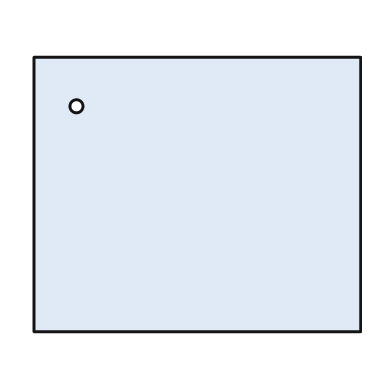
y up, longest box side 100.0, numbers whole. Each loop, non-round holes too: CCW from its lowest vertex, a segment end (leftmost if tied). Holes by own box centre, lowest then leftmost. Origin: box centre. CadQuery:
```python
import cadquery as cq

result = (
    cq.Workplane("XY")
    .moveTo(-50.0, -42.0)
    .lineTo(50.0, -42.0)
    .lineTo(50.0, 42.0)
    .lineTo(-50.0, 42.0)
    .close()
    .moveTo(-37.0, 27.0)
    .circle(2.0)
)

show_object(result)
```